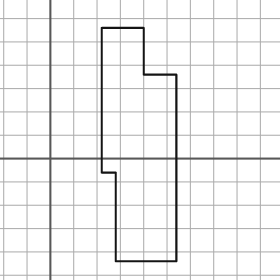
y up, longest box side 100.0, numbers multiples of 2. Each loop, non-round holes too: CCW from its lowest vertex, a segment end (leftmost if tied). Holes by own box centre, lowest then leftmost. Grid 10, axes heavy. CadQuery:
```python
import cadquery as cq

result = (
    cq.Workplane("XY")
    .moveTo(28.0, -44.0)
    .lineTo(54.0, -44.0)
    .lineTo(54.0, 36.0)
    .lineTo(40.0, 36.0)
    .lineTo(40.0, 56.0)
    .lineTo(22.0, 56.0)
    .lineTo(22.0, -6.0)
    .lineTo(28.0, -6.0)
    .close()
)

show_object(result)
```